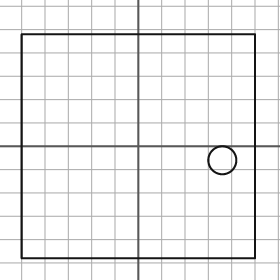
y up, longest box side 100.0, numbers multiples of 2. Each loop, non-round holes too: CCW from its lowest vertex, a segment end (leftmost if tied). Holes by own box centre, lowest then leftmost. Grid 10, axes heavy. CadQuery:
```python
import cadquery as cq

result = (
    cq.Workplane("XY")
    .moveTo(-50.0, -48.0)
    .lineTo(50.0, -48.0)
    .lineTo(50.0, 48.0)
    .lineTo(-50.0, 48.0)
    .close()
    .moveTo(36.0, -6.0)
    .circle(6.0)
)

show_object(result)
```